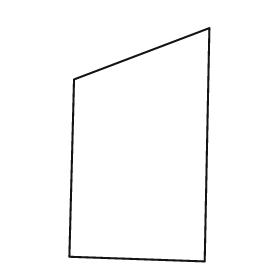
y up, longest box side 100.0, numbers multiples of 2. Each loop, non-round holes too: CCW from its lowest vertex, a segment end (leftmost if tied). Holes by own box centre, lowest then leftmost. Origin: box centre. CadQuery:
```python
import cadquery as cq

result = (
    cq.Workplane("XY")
    .moveTo(28.0, -50.0)
    .lineTo(30.0, 50.0)
    .lineTo(-28.0, 28.0)
    .lineTo(-30.0, -48.0)
    .close()
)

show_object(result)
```